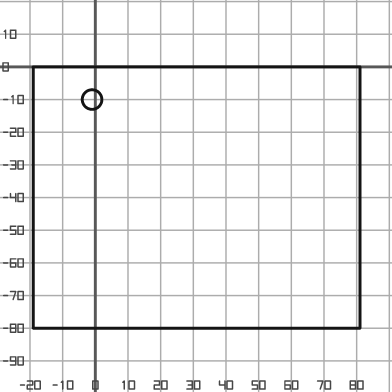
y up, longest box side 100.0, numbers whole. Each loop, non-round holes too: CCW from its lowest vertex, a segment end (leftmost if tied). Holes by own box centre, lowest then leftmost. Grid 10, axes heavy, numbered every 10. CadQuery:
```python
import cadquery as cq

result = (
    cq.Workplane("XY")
    .moveTo(-19.0, -80.0)
    .lineTo(81.0, -80.0)
    .lineTo(81.0, 0.0)
    .lineTo(-19.0, 0.0)
    .close()
    .moveTo(-1.0, -10.0)
    .circle(3.0)
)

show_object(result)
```